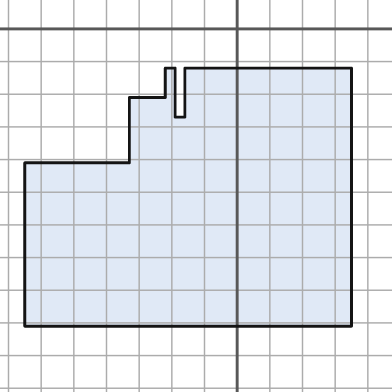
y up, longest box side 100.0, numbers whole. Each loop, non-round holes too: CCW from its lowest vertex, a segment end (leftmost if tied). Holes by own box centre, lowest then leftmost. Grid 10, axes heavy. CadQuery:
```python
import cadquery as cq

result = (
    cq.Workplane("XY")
    .moveTo(-65.0, -91.0)
    .lineTo(35.0, -91.0)
    .lineTo(35.0, -12.0)
    .lineTo(-16.0, -12.0)
    .lineTo(-16.0, -27.0)
    .lineTo(-19.0, -27.0)
    .lineTo(-19.0, -12.0)
    .lineTo(-22.0, -12.0)
    .lineTo(-22.0, -21.0)
    .lineTo(-33.0, -21.0)
    .lineTo(-33.0, -41.0)
    .lineTo(-65.0, -41.0)
    .close()
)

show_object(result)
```